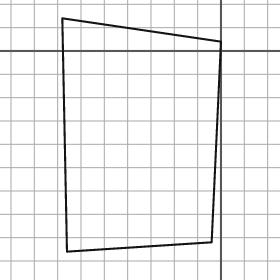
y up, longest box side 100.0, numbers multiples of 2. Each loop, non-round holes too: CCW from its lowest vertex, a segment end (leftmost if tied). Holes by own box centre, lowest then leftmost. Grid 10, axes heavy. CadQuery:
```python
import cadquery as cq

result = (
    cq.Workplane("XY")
    .moveTo(-66.0, -86.0)
    .lineTo(-4.0, -82.0)
    .lineTo(0.0, 4.0)
    .lineTo(-68.0, 14.0)
    .close()
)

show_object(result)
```